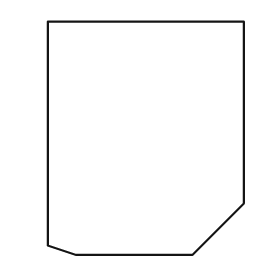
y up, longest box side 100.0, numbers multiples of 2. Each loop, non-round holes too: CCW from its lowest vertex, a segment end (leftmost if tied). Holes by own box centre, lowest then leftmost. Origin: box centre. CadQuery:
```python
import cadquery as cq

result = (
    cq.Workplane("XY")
    .moveTo(-30.0, -50.0)
    .lineTo(20.0, -50.0)
    .lineTo(42.0, -28.0)
    .lineTo(42.0, 50.0)
    .lineTo(-42.0, 50.0)
    .lineTo(-42.0, -46.0)
    .close()
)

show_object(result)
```